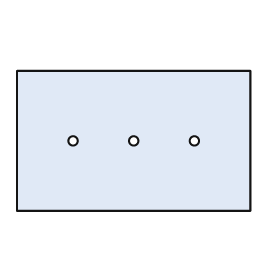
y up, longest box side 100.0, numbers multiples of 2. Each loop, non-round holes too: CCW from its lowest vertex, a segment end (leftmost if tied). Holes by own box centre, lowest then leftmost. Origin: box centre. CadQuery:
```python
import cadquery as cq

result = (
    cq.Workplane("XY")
    .moveTo(-50.0, -30.0)
    .lineTo(50.0, -30.0)
    .lineTo(50.0, 30.0)
    .lineTo(-50.0, 30.0)
    .close()
    .moveTo(-26.0, 0.0)
    .circle(2.0)
    .moveTo(0.0, 0.0)
    .circle(2.0)
    .moveTo(26.0, 0.0)
    .circle(2.0)
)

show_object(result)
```